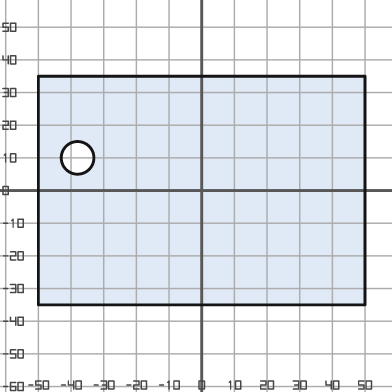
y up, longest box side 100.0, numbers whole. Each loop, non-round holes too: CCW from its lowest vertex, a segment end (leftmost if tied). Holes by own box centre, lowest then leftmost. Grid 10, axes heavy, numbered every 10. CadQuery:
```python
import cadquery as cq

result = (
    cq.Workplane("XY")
    .moveTo(-50.0, -35.0)
    .lineTo(50.0, -35.0)
    .lineTo(50.0, 35.0)
    .lineTo(-50.0, 35.0)
    .close()
    .moveTo(-38.0, 10.0)
    .circle(5.0)
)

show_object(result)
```